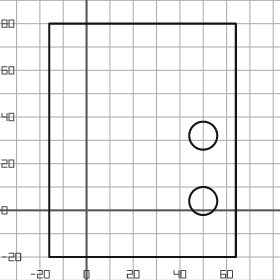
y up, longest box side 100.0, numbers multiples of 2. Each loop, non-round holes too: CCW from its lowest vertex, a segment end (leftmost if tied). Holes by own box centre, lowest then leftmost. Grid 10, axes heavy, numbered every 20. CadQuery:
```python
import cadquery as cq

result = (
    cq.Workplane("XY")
    .moveTo(-16.0, -20.0)
    .lineTo(64.0, -20.0)
    .lineTo(64.0, 80.0)
    .lineTo(-16.0, 80.0)
    .close()
    .moveTo(50.0, 4.0)
    .circle(6.0)
    .moveTo(50.0, 32.0)
    .circle(6.0)
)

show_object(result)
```